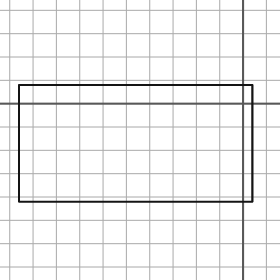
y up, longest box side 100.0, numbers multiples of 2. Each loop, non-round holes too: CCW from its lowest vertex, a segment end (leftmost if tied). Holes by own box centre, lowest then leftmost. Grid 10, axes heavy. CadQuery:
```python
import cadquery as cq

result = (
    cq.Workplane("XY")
    .moveTo(-96.0, -42.0)
    .lineTo(4.0, -42.0)
    .lineTo(4.0, 8.0)
    .lineTo(-96.0, 8.0)
    .close()
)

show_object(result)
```